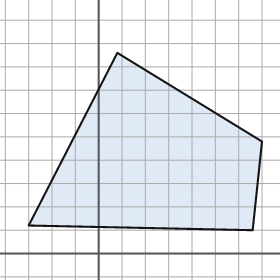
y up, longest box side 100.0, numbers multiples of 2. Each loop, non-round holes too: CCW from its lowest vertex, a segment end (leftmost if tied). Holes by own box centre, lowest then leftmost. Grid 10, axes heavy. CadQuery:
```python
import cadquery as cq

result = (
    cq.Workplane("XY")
    .moveTo(66.0, 10.0)
    .lineTo(70.0, 48.0)
    .lineTo(8.0, 86.0)
    .lineTo(-30.0, 12.0)
    .close()
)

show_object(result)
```